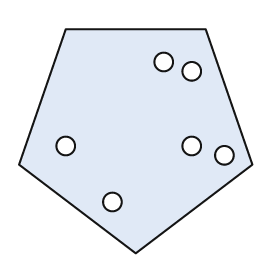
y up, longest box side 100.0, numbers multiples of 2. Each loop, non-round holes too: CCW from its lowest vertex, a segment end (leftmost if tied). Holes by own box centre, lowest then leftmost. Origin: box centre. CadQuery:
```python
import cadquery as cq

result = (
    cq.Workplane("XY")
    .moveTo(0.0, -48.0)
    .lineTo(50.0, -10.0)
    .lineTo(30.0, 48.0)
    .lineTo(-30.0, 48.0)
    .lineTo(-50.0, -10.0)
    .close()
    .moveTo(-10.0, -26.0)
    .circle(4.0)
    .moveTo(38.0, -6.0)
    .circle(4.0)
    .moveTo(-30.0, -2.0)
    .circle(4.0)
    .moveTo(24.0, -2.0)
    .circle(4.0)
    .moveTo(24.0, 30.0)
    .circle(4.0)
    .moveTo(12.0, 34.0)
    .circle(4.0)
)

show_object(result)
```